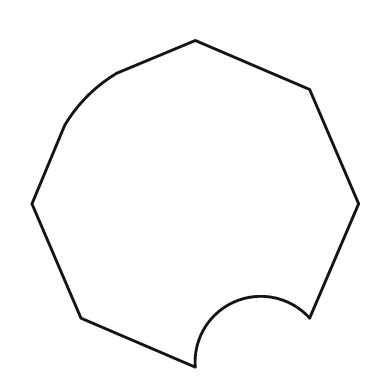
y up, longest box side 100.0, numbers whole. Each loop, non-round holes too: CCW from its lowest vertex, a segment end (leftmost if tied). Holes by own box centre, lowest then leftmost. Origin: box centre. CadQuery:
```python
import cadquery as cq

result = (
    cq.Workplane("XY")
    .moveTo(0.0, -50.0)
    .threePointArc((12.0, -30.0), (35.0, -35.0))
    .lineTo(50.0, 0.0)
    .lineTo(35.0, 35.0)
    .lineTo(0.0, 50.0)
    .lineTo(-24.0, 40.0)
    .threePointArc((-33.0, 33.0), (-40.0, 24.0))
    .lineTo(-50.0, 0.0)
    .lineTo(-35.0, -35.0)
    .close()
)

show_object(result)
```